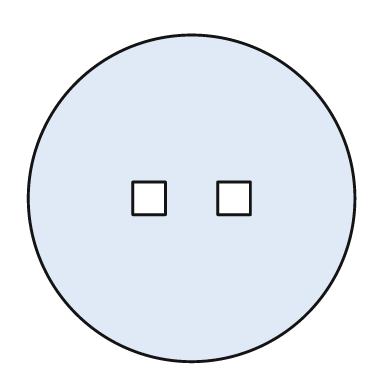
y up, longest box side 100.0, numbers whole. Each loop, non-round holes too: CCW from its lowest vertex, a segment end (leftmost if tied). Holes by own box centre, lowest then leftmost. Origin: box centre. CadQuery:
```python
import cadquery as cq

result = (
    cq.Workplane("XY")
    .moveTo(0.0, 0.0)
    .circle(50.0)
    .moveTo(-18.0, -5.0)
    .lineTo(-8.0, -5.0)
    .lineTo(-8.0, 5.0)
    .lineTo(-18.0, 5.0)
    .close()
    .moveTo(8.0, -5.0)
    .lineTo(18.0, -5.0)
    .lineTo(18.0, 5.0)
    .lineTo(8.0, 5.0)
    .close()
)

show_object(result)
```